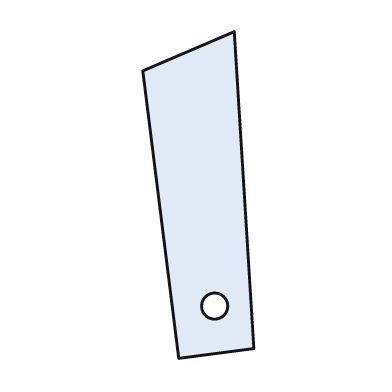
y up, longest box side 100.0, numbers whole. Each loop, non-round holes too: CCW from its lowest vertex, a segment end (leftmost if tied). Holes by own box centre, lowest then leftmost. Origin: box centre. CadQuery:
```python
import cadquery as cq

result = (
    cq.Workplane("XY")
    .moveTo(-6.0, -50.0)
    .lineTo(17.0, -47.0)
    .lineTo(11.0, 50.0)
    .lineTo(-17.0, 38.0)
    .close()
    .moveTo(5.0, -34.0)
    .circle(4.0)
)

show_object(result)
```